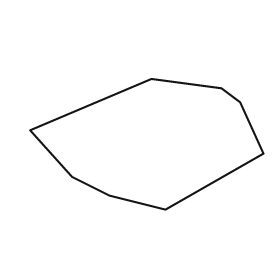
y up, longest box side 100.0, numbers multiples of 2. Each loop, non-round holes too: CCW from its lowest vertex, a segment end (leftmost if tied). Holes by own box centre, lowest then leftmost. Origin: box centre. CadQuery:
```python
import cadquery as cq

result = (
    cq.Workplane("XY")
    .moveTo(8.0, -28.0)
    .lineTo(50.0, -4.0)
    .lineTo(40.0, 18.0)
    .lineTo(32.0, 24.0)
    .lineTo(2.0, 28.0)
    .lineTo(-50.0, 6.0)
    .lineTo(-32.0, -14.0)
    .lineTo(-16.0, -22.0)
    .close()
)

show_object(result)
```